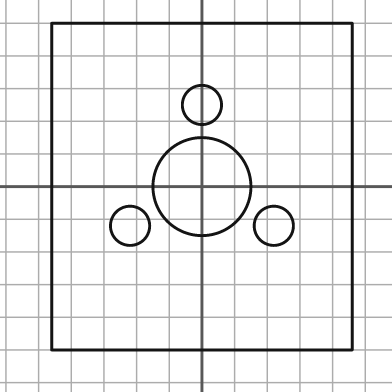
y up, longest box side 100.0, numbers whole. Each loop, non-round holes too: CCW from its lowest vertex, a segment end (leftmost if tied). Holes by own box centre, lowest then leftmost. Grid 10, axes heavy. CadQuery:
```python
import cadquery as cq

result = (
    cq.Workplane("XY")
    .moveTo(-46.0, -50.0)
    .lineTo(46.0, -50.0)
    .lineTo(46.0, 50.0)
    .lineTo(-46.0, 50.0)
    .close()
    .moveTo(-22.0, -12.0)
    .circle(6.0)
    .moveTo(22.0, -12.0)
    .circle(6.0)
    .moveTo(0.0, 0.0)
    .circle(15.0)
    .moveTo(0.0, 25.0)
    .circle(6.0)
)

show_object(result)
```